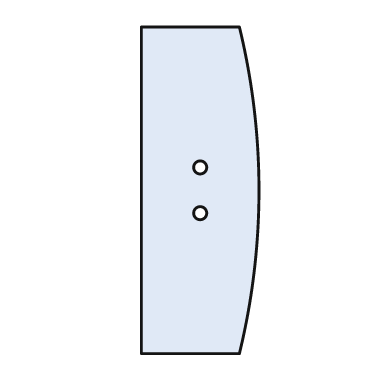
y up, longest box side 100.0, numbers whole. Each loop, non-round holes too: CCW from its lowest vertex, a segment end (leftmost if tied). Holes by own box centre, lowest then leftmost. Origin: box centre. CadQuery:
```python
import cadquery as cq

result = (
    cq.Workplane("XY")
    .moveTo(-18.0, -50.0)
    .lineTo(12.0, -50.0)
    .threePointArc((18.0, 0.0), (12.0, 50.0))
    .lineTo(-18.0, 50.0)
    .close()
    .moveTo(0.0, -7.0)
    .circle(2.0)
    .moveTo(0.0, 7.0)
    .circle(2.0)
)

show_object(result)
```